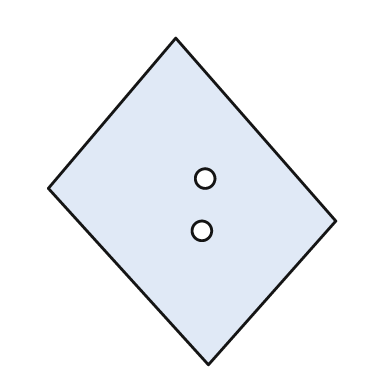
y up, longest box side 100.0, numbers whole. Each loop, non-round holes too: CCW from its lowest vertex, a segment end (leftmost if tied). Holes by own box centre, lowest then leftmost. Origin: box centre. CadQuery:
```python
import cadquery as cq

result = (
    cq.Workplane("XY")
    .moveTo(5.0, -50.0)
    .lineTo(44.0, -6.0)
    .lineTo(-5.0, 50.0)
    .lineTo(-44.0, 4.0)
    .close()
    .moveTo(3.0, -9.0)
    .circle(3.0)
    .moveTo(4.0, 7.0)
    .circle(3.0)
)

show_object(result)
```